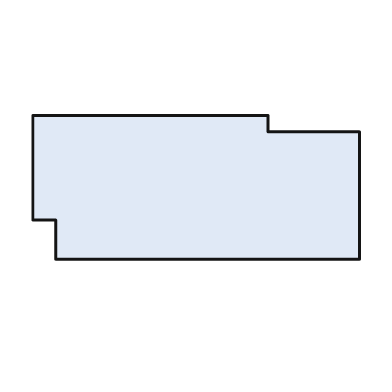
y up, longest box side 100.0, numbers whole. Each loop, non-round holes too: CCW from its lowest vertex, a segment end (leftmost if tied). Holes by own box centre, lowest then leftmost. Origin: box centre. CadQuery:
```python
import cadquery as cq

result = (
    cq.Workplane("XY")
    .moveTo(-43.0, -22.0)
    .lineTo(50.0, -22.0)
    .lineTo(50.0, 17.0)
    .lineTo(22.0, 17.0)
    .lineTo(22.0, 22.0)
    .lineTo(-50.0, 22.0)
    .lineTo(-50.0, -10.0)
    .lineTo(-43.0, -10.0)
    .close()
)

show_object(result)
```